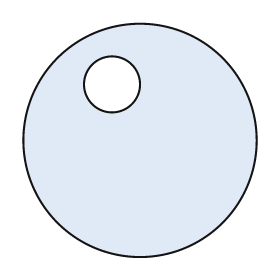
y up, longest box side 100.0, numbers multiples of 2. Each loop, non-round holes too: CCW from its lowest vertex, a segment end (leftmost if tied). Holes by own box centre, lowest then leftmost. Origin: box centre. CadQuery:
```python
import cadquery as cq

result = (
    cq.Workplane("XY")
    .moveTo(0.0, 0.0)
    .circle(50.0)
    .moveTo(-12.0, 24.0)
    .circle(12.0)
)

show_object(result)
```